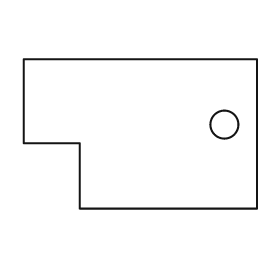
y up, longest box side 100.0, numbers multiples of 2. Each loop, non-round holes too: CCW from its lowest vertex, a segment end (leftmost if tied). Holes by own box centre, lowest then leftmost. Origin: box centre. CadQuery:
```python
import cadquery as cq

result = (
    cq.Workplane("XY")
    .moveTo(-26.0, -32.0)
    .lineTo(50.0, -32.0)
    .lineTo(50.0, 32.0)
    .lineTo(-50.0, 32.0)
    .lineTo(-50.0, -4.0)
    .lineTo(-26.0, -4.0)
    .close()
    .moveTo(36.0, 4.0)
    .circle(6.0)
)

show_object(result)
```